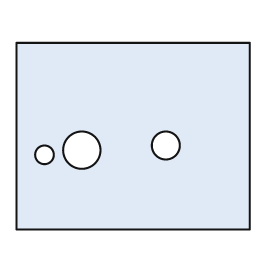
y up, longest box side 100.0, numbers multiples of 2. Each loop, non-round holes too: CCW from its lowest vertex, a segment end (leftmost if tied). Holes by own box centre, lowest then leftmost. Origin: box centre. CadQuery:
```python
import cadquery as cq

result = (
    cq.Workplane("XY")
    .moveTo(-50.0, -40.0)
    .lineTo(50.0, -40.0)
    .lineTo(50.0, 40.0)
    .lineTo(-50.0, 40.0)
    .close()
    .moveTo(-38.0, -8.0)
    .circle(4.0)
    .moveTo(-22.0, -6.0)
    .circle(8.0)
    .moveTo(14.0, -4.0)
    .circle(6.0)
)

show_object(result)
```